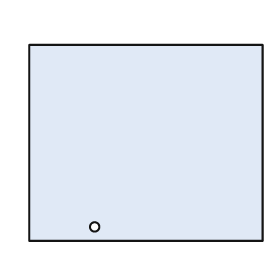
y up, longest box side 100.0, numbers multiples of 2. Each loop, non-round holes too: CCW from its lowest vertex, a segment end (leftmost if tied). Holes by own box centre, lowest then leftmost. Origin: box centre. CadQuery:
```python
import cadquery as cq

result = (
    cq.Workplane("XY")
    .moveTo(-50.0, -42.0)
    .lineTo(50.0, -42.0)
    .lineTo(50.0, 42.0)
    .lineTo(-50.0, 42.0)
    .close()
    .moveTo(-22.0, -36.0)
    .circle(2.0)
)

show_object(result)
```